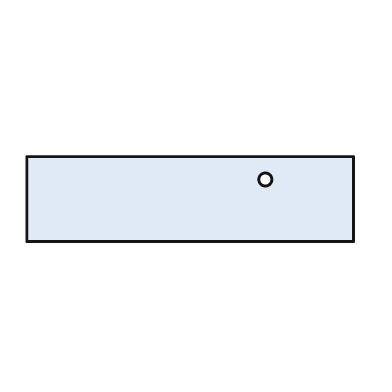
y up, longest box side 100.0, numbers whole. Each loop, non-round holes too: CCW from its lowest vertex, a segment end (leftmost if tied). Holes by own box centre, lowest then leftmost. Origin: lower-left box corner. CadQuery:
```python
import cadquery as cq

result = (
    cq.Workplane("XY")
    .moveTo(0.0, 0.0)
    .lineTo(100.0, 0.0)
    .lineTo(100.0, 26.0)
    .lineTo(0.0, 26.0)
    .close()
    .moveTo(73.0, 19.0)
    .circle(2.0)
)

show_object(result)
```